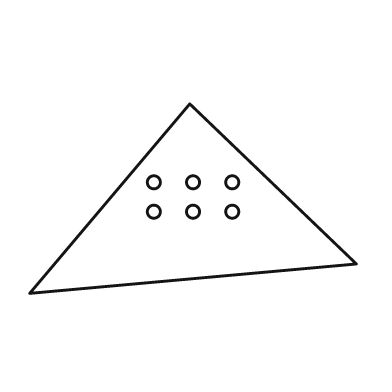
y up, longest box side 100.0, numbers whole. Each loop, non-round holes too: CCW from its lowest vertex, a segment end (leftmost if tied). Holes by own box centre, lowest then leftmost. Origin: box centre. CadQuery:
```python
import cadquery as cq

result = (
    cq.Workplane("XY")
    .moveTo(-50.0, -29.0)
    .lineTo(50.0, -20.0)
    .lineTo(-1.0, 29.0)
    .close()
    .moveTo(-12.0, -4.0)
    .circle(2.0)
    .moveTo(0.0, -4.0)
    .circle(2.0)
    .moveTo(12.0, -4.0)
    .circle(2.0)
    .moveTo(-12.0, 5.0)
    .circle(2.0)
    .moveTo(0.0, 5.0)
    .circle(2.0)
    .moveTo(12.0, 5.0)
    .circle(2.0)
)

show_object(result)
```